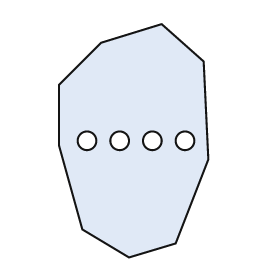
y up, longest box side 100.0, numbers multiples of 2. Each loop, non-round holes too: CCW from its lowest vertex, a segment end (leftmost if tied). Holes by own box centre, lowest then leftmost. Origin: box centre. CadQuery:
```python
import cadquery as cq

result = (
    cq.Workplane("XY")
    .moveTo(-2.0, -50.0)
    .lineTo(18.0, -44.0)
    .lineTo(32.0, -8.0)
    .lineTo(30.0, 34.0)
    .lineTo(12.0, 50.0)
    .lineTo(-14.0, 42.0)
    .lineTo(-32.0, 24.0)
    .lineTo(-32.0, -2.0)
    .lineTo(-22.0, -38.0)
    .close()
    .moveTo(-20.0, 0.0)
    .circle(4.0)
    .moveTo(-6.0, 0.0)
    .circle(4.0)
    .moveTo(8.0, 0.0)
    .circle(4.0)
    .moveTo(22.0, 0.0)
    .circle(4.0)
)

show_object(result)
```